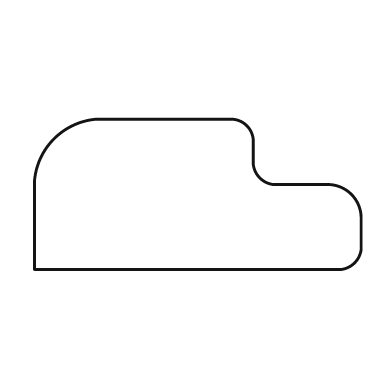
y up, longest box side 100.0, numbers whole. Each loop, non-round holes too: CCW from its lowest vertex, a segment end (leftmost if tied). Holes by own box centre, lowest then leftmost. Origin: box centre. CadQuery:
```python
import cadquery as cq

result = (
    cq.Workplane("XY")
    .moveTo(-50.0, -23.0)
    .lineTo(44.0, -23.0)
    .threePointArc((48.0, -21.0), (50.0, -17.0))
    .lineTo(50.0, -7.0)
    .threePointArc((47.0, 0.0), (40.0, 3.0))
    .lineTo(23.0, 3.0)
    .threePointArc((19.0, 5.0), (17.0, 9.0))
    .lineTo(17.0, 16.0)
    .threePointArc((15.0, 21.0), (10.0, 23.0))
    .lineTo(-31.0, 23.0)
    .threePointArc((-44.0, 17.0), (-50.0, 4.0))
    .close()
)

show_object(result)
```